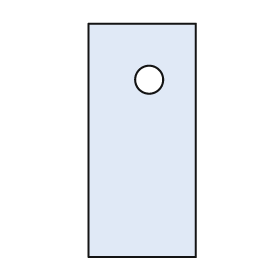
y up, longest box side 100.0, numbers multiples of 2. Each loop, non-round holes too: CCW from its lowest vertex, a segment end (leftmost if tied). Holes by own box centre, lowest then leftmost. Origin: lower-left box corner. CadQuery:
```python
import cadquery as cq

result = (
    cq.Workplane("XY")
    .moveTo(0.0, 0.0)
    .lineTo(46.0, 0.0)
    .lineTo(46.0, 100.0)
    .lineTo(0.0, 100.0)
    .close()
    .moveTo(26.0, 76.0)
    .circle(6.0)
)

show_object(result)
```